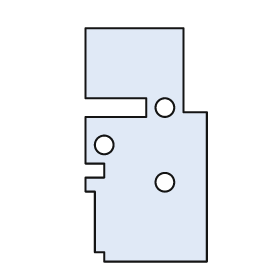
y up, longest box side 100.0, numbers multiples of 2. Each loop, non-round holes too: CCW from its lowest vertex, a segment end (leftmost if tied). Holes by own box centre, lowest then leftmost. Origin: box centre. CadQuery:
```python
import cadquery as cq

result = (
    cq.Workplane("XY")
    .moveTo(-18.0, -50.0)
    .lineTo(26.0, -50.0)
    .lineTo(26.0, 14.0)
    .lineTo(16.0, 14.0)
    .lineTo(16.0, 50.0)
    .lineTo(-26.0, 50.0)
    .lineTo(-26.0, 20.0)
    .lineTo(0.0, 20.0)
    .lineTo(0.0, 12.0)
    .lineTo(-26.0, 12.0)
    .lineTo(-26.0, -8.0)
    .lineTo(-18.0, -8.0)
    .lineTo(-18.0, -14.0)
    .lineTo(-26.0, -14.0)
    .lineTo(-26.0, -20.0)
    .lineTo(-22.0, -20.0)
    .lineTo(-22.0, -46.0)
    .lineTo(-18.0, -46.0)
    .close()
    .moveTo(8.0, -16.0)
    .circle(4.0)
    .moveTo(-18.0, 0.0)
    .circle(4.0)
    .moveTo(8.0, 16.0)
    .circle(4.0)
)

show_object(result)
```